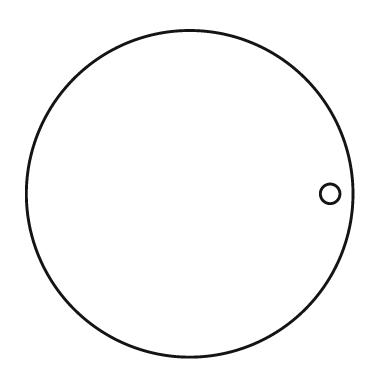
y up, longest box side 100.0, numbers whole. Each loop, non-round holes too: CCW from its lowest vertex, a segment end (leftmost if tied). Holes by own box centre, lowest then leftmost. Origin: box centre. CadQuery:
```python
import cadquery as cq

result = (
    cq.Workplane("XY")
    .moveTo(0.0, 0.0)
    .circle(50.0)
    .moveTo(43.0, 0.0)
    .circle(3.0)
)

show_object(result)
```